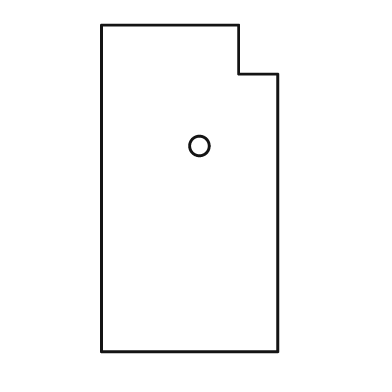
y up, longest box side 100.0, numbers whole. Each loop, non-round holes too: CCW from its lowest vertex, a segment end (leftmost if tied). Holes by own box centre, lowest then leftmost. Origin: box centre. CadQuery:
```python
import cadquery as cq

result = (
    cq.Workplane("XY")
    .moveTo(-27.0, -50.0)
    .lineTo(27.0, -50.0)
    .lineTo(27.0, 35.0)
    .lineTo(15.0, 35.0)
    .lineTo(15.0, 50.0)
    .lineTo(-27.0, 50.0)
    .close()
    .moveTo(3.0, 13.0)
    .circle(3.0)
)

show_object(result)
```